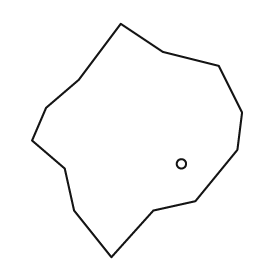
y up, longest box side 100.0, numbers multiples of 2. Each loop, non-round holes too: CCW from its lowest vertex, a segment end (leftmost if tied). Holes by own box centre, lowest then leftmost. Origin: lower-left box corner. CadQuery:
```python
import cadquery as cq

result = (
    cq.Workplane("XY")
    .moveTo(34.0, 0.0)
    .lineTo(52.0, 20.0)
    .lineTo(70.0, 24.0)
    .lineTo(88.0, 46.0)
    .lineTo(90.0, 62.0)
    .lineTo(80.0, 82.0)
    .lineTo(56.0, 88.0)
    .lineTo(38.0, 100.0)
    .lineTo(20.0, 76.0)
    .lineTo(6.0, 64.0)
    .lineTo(0.0, 50.0)
    .lineTo(14.0, 38.0)
    .lineTo(18.0, 20.0)
    .close()
    .moveTo(64.0, 40.0)
    .circle(2.0)
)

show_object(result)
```